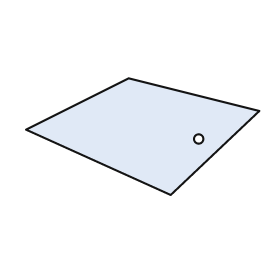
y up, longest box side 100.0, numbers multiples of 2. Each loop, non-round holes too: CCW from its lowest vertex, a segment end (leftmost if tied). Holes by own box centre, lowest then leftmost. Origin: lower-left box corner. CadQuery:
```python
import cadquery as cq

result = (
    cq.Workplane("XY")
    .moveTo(62.0, 0.0)
    .lineTo(100.0, 36.0)
    .lineTo(44.0, 50.0)
    .lineTo(0.0, 28.0)
    .close()
    .moveTo(74.0, 24.0)
    .circle(2.0)
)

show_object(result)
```